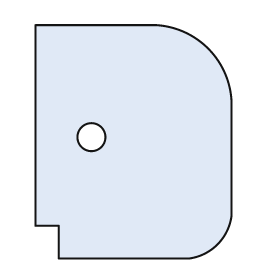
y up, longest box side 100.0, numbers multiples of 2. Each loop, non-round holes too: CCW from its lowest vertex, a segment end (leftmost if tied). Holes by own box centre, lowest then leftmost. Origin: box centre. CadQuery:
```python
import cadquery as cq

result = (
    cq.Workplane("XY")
    .moveTo(-32.0, -50.0)
    .lineTo(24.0, -50.0)
    .threePointArc((36.0, -44.0), (42.0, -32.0))
    .lineTo(42.0, 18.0)
    .threePointArc((32.0, 40.0), (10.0, 50.0))
    .lineTo(-42.0, 50.0)
    .lineTo(-42.0, -36.0)
    .lineTo(-32.0, -36.0)
    .close()
    .moveTo(-18.0, 2.0)
    .circle(6.0)
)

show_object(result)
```